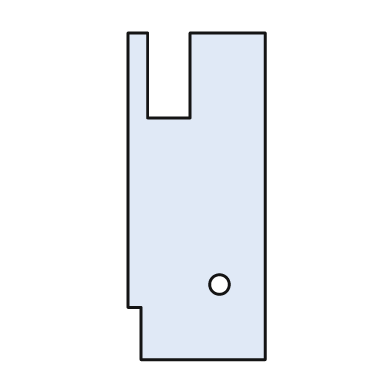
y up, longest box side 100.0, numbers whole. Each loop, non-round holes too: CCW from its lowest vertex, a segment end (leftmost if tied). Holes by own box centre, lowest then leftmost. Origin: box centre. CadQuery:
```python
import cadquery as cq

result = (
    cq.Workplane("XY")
    .moveTo(-17.0, -50.0)
    .lineTo(21.0, -50.0)
    .lineTo(21.0, 50.0)
    .lineTo(-2.0, 50.0)
    .lineTo(-2.0, 24.0)
    .lineTo(-15.0, 24.0)
    .lineTo(-15.0, 50.0)
    .lineTo(-21.0, 50.0)
    .lineTo(-21.0, -34.0)
    .lineTo(-17.0, -34.0)
    .close()
    .moveTo(7.0, -27.0)
    .circle(3.0)
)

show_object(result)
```